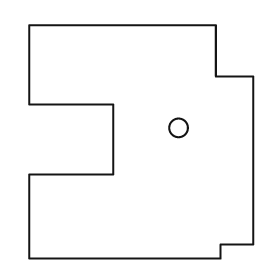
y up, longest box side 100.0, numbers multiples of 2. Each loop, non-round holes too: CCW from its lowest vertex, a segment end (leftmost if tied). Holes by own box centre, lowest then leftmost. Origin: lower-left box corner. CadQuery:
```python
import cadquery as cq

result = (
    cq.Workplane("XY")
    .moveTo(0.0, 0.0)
    .lineTo(82.0, 0.0)
    .lineTo(82.0, 6.0)
    .lineTo(96.0, 6.0)
    .lineTo(96.0, 78.0)
    .lineTo(80.0, 78.0)
    .lineTo(80.0, 100.0)
    .lineTo(0.0, 100.0)
    .lineTo(0.0, 66.0)
    .lineTo(36.0, 66.0)
    .lineTo(36.0, 36.0)
    .lineTo(0.0, 36.0)
    .close()
    .moveTo(64.0, 56.0)
    .circle(4.0)
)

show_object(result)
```